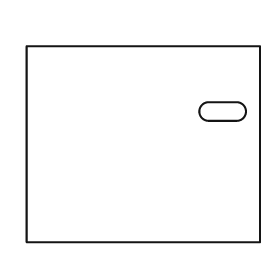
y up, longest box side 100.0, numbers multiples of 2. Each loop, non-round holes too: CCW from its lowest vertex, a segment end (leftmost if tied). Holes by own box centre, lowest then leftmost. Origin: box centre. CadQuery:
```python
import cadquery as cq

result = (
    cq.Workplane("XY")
    .moveTo(-50.0, -42.0)
    .lineTo(50.0, -42.0)
    .lineTo(50.0, 42.0)
    .lineTo(-50.0, 42.0)
    .close()
    .moveTo(28.0, 10.0)
    .lineTo(40.0, 10.0)
    .threePointArc((44.0, 14.0), (40.0, 18.0))
    .lineTo(28.0, 18.0)
    .threePointArc((24.0, 14.0), (28.0, 10.0))
    .close()
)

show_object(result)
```